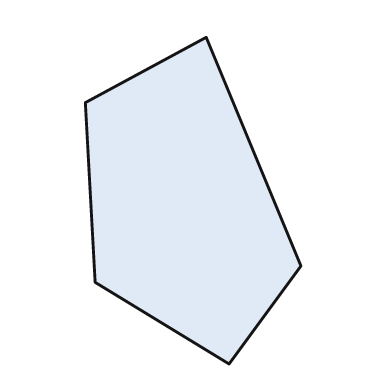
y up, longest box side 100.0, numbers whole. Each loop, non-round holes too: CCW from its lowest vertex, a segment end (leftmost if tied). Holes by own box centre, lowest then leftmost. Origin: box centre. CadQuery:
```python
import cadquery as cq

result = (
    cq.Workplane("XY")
    .moveTo(11.0, -50.0)
    .lineTo(33.0, -20.0)
    .lineTo(4.0, 50.0)
    .lineTo(-33.0, 30.0)
    .lineTo(-30.0, -25.0)
    .close()
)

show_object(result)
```